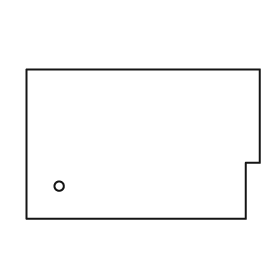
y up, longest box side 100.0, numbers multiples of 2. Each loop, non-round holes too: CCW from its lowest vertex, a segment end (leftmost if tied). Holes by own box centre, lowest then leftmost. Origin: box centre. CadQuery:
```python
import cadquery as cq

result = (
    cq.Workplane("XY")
    .moveTo(-50.0, -32.0)
    .lineTo(44.0, -32.0)
    .lineTo(44.0, -8.0)
    .lineTo(50.0, -8.0)
    .lineTo(50.0, 32.0)
    .lineTo(-50.0, 32.0)
    .close()
    .moveTo(-36.0, -18.0)
    .circle(2.0)
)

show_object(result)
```